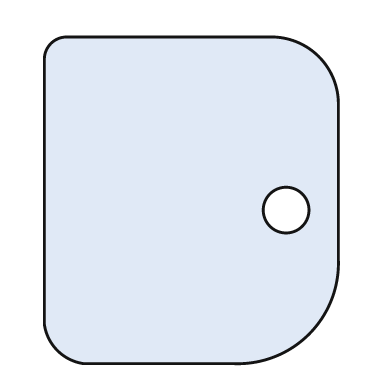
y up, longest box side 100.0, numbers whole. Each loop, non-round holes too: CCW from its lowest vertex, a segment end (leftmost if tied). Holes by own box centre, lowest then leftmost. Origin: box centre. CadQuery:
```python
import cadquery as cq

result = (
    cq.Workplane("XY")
    .moveTo(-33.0, -50.0)
    .lineTo(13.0, -50.0)
    .threePointArc((36.0, -41.0), (45.0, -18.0))
    .lineTo(45.0, 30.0)
    .threePointArc((39.0, 44.0), (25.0, 50.0))
    .lineTo(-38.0, 50.0)
    .threePointArc((-43.0, 48.0), (-45.0, 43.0))
    .lineTo(-45.0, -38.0)
    .threePointArc((-41.0, -46.0), (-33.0, -50.0))
    .close()
    .moveTo(29.0, -3.0)
    .circle(7.0)
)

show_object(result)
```